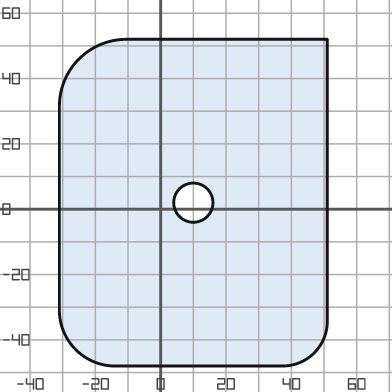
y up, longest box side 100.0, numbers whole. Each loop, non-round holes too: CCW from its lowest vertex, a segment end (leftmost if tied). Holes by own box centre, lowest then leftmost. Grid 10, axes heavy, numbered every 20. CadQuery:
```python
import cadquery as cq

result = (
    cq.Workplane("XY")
    .moveTo(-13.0, -48.0)
    .lineTo(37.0, -48.0)
    .threePointArc((47.0, -44.0), (51.0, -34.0))
    .lineTo(51.0, 52.0)
    .lineTo(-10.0, 52.0)
    .threePointArc((-25.0, 46.0), (-31.0, 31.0))
    .lineTo(-31.0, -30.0)
    .threePointArc((-26.0, -43.0), (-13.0, -48.0))
    .close()
    .moveTo(10.0, 2.0)
    .circle(6.0)
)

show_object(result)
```